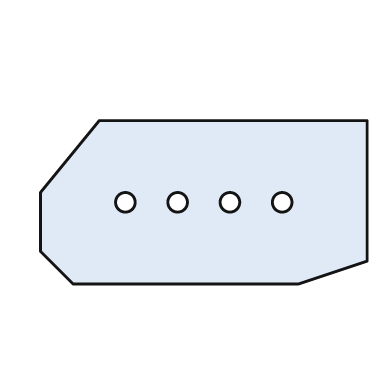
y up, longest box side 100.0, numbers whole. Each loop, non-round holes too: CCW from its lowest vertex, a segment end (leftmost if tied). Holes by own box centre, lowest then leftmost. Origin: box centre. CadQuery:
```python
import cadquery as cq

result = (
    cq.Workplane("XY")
    .moveTo(-40.0, -25.0)
    .lineTo(29.0, -25.0)
    .lineTo(50.0, -18.0)
    .lineTo(50.0, 25.0)
    .lineTo(-32.0, 25.0)
    .lineTo(-50.0, 3.0)
    .lineTo(-50.0, -15.0)
    .close()
    .moveTo(-24.0, 0.0)
    .circle(3.0)
    .moveTo(-8.0, 0.0)
    .circle(3.0)
    .moveTo(8.0, 0.0)
    .circle(3.0)
    .moveTo(24.0, 0.0)
    .circle(3.0)
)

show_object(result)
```